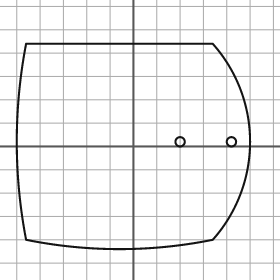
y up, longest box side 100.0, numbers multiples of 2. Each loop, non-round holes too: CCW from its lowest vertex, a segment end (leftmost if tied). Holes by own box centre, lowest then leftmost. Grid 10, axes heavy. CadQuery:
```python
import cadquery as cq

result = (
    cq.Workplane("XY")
    .moveTo(-46.0, -40.0)
    .threePointArc((-6.0, -44.0), (34.0, -40.0))
    .threePointArc((50.0, 2.0), (34.0, 44.0))
    .lineTo(-46.0, 44.0)
    .threePointArc((-50.0, 2.0), (-46.0, -40.0))
    .close()
    .moveTo(20.0, 2.0)
    .circle(2.0)
    .moveTo(42.0, 2.0)
    .circle(2.0)
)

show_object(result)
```